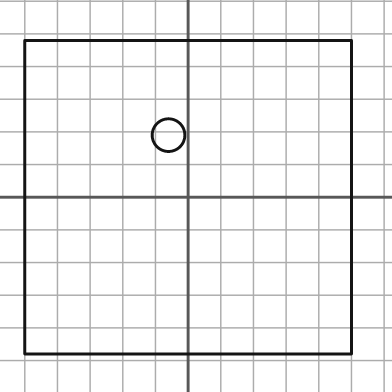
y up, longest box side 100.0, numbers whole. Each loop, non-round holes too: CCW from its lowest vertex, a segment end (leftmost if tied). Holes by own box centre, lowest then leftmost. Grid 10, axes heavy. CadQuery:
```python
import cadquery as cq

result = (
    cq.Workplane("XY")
    .moveTo(-50.0, -48.0)
    .lineTo(50.0, -48.0)
    .lineTo(50.0, 48.0)
    .lineTo(-50.0, 48.0)
    .close()
    .moveTo(-6.0, 19.0)
    .circle(5.0)
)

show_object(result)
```